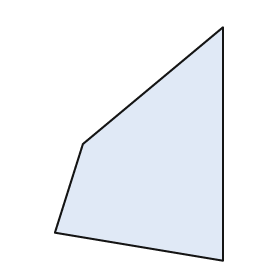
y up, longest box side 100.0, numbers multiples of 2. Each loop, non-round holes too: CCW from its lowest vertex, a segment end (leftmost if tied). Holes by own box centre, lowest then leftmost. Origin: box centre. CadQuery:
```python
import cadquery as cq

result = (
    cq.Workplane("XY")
    .moveTo(36.0, -50.0)
    .lineTo(36.0, 50.0)
    .lineTo(-24.0, 0.0)
    .lineTo(-36.0, -38.0)
    .close()
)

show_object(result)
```